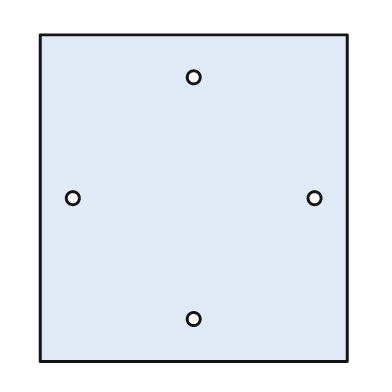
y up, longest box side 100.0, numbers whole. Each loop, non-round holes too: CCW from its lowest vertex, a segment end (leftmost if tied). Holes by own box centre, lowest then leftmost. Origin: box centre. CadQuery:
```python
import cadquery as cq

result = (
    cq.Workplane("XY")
    .moveTo(-47.0, -50.0)
    .lineTo(47.0, -50.0)
    .lineTo(47.0, 50.0)
    .lineTo(-47.0, 50.0)
    .close()
    .moveTo(0.0, -37.0)
    .circle(2.0)
    .moveTo(-37.0, 0.0)
    .circle(2.0)
    .moveTo(37.0, 0.0)
    .circle(2.0)
    .moveTo(0.0, 37.0)
    .circle(2.0)
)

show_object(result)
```